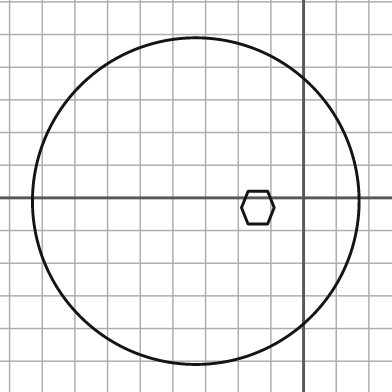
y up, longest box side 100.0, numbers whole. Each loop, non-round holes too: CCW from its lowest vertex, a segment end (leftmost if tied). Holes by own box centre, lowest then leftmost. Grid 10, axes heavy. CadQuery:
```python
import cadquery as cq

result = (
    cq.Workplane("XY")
    .moveTo(-33.0, -1.0)
    .circle(50.0)
    .moveTo(-17.0, -8.0)
    .lineTo(-11.0, -8.0)
    .lineTo(-9.0, -3.0)
    .lineTo(-11.0, 2.0)
    .lineTo(-17.0, 2.0)
    .lineTo(-19.0, -3.0)
    .close()
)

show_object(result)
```